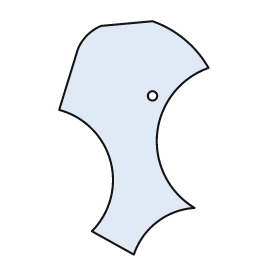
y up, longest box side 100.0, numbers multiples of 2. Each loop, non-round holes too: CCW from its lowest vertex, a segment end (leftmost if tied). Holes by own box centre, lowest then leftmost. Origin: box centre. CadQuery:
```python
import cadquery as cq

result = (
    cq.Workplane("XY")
    .moveTo(0.0, -50.0)
    .threePointArc((10.0, -36.0), (26.0, -30.0))
    .threePointArc((10.0, 2.0), (32.0, 30.0))
    .threePointArc((22.0, 42.0), (8.0, 50.0))
    .lineTo(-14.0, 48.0)
    .threePointArc((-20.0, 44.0), (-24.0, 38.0))
    .lineTo(-32.0, 12.0)
    .threePointArc((-10.0, -10.0), (-18.0, -40.0))
    .close()
    .moveTo(8.0, 18.0)
    .circle(2.0)
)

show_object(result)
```